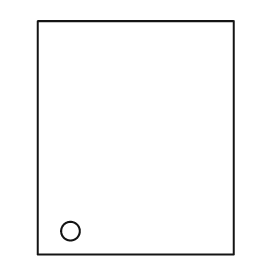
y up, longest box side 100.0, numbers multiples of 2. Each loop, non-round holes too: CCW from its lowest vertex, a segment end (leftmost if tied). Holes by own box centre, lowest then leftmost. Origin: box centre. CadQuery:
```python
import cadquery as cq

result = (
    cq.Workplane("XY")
    .moveTo(-42.0, -50.0)
    .lineTo(42.0, -50.0)
    .lineTo(42.0, 50.0)
    .lineTo(-42.0, 50.0)
    .close()
    .moveTo(-28.0, -40.0)
    .circle(4.0)
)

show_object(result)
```